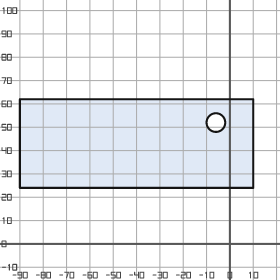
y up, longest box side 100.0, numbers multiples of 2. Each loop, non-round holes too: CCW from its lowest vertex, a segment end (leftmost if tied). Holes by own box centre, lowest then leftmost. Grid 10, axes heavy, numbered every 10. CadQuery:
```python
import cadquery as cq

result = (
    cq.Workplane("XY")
    .moveTo(-90.0, 24.0)
    .lineTo(10.0, 24.0)
    .lineTo(10.0, 62.0)
    .lineTo(-90.0, 62.0)
    .close()
    .moveTo(-6.0, 52.0)
    .circle(4.0)
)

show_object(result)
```